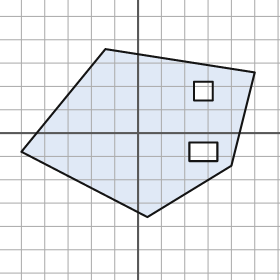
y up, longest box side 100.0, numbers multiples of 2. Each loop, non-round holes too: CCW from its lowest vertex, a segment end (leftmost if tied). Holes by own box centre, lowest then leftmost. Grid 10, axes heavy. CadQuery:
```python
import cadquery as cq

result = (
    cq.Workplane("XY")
    .moveTo(4.0, -36.0)
    .lineTo(40.0, -14.0)
    .lineTo(50.0, 26.0)
    .lineTo(-14.0, 36.0)
    .lineTo(-50.0, -8.0)
    .close()
    .moveTo(22.0, -12.0)
    .lineTo(34.0, -12.0)
    .lineTo(34.0, -4.0)
    .lineTo(22.0, -4.0)
    .close()
    .moveTo(24.0, 14.0)
    .lineTo(32.0, 14.0)
    .lineTo(32.0, 22.0)
    .lineTo(24.0, 22.0)
    .close()
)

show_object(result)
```